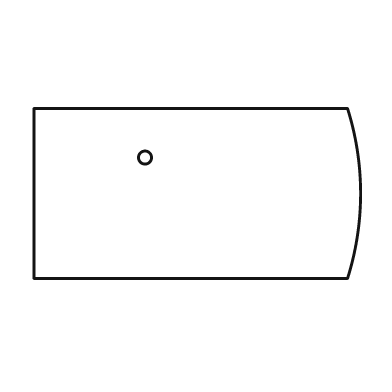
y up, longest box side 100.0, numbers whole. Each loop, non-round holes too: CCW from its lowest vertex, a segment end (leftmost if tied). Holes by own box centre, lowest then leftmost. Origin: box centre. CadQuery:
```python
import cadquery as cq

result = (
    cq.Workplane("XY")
    .moveTo(-50.0, -26.0)
    .lineTo(46.0, -26.0)
    .threePointArc((50.0, 0.0), (46.0, 26.0))
    .lineTo(-50.0, 26.0)
    .close()
    .moveTo(-16.0, 11.0)
    .circle(2.0)
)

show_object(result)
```